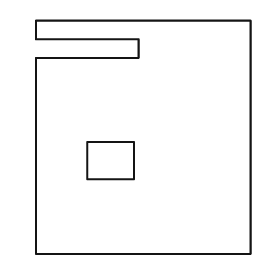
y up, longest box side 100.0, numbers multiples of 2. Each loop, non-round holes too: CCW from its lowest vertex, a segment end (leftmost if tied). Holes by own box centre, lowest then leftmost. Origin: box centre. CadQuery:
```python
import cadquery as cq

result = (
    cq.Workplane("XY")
    .moveTo(-46.0, -50.0)
    .lineTo(46.0, -50.0)
    .lineTo(46.0, 50.0)
    .lineTo(-46.0, 50.0)
    .lineTo(-46.0, 42.0)
    .lineTo(-2.0, 42.0)
    .lineTo(-2.0, 34.0)
    .lineTo(-46.0, 34.0)
    .close()
    .moveTo(-24.0, -18.0)
    .lineTo(-4.0, -18.0)
    .lineTo(-4.0, -2.0)
    .lineTo(-24.0, -2.0)
    .close()
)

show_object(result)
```